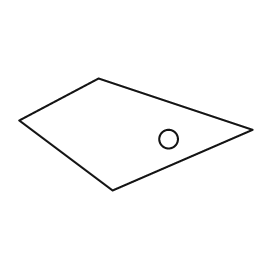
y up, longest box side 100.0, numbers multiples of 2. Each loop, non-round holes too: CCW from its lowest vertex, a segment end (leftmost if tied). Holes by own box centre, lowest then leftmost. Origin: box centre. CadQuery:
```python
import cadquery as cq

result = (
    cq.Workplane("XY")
    .moveTo(-10.0, -24.0)
    .lineTo(50.0, 2.0)
    .lineTo(-16.0, 24.0)
    .lineTo(-50.0, 6.0)
    .close()
    .moveTo(14.0, -2.0)
    .circle(4.0)
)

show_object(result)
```